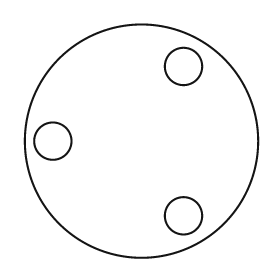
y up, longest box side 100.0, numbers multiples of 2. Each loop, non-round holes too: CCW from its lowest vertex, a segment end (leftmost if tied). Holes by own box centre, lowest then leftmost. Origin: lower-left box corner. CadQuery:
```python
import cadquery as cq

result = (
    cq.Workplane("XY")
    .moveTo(50.0, 50.0)
    .circle(50.0)
    .moveTo(68.0, 18.0)
    .circle(8.0)
    .moveTo(12.0, 50.0)
    .circle(8.0)
    .moveTo(68.0, 82.0)
    .circle(8.0)
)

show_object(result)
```